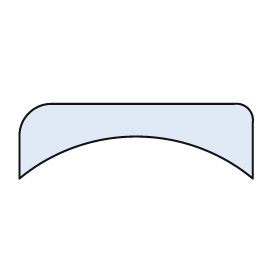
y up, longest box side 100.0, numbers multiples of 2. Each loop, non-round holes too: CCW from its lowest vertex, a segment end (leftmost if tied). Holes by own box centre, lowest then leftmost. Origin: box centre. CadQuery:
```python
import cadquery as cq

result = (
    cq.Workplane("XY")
    .moveTo(-50.0, -16.0)
    .threePointArc((0.0, 2.0), (50.0, -16.0))
    .lineTo(50.0, 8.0)
    .threePointArc((48.0, 14.0), (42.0, 16.0))
    .lineTo(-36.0, 16.0)
    .threePointArc((-46.0, 12.0), (-50.0, 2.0))
    .close()
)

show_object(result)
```